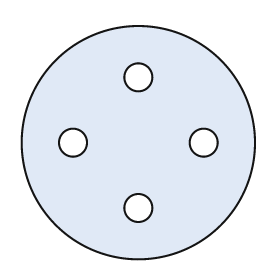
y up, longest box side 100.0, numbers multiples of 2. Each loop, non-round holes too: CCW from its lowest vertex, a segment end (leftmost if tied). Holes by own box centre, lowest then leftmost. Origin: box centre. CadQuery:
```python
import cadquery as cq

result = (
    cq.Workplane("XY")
    .moveTo(0.0, 0.0)
    .circle(50.0)
    .moveTo(0.0, -28.0)
    .circle(6.0)
    .moveTo(-28.0, 0.0)
    .circle(6.0)
    .moveTo(28.0, 0.0)
    .circle(6.0)
    .moveTo(0.0, 28.0)
    .circle(6.0)
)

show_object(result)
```